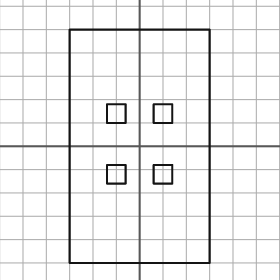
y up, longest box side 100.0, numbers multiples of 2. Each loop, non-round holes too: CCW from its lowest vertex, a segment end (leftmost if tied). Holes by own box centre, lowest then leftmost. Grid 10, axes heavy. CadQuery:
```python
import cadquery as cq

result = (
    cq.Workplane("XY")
    .moveTo(-30.0, -50.0)
    .lineTo(30.0, -50.0)
    .lineTo(30.0, 50.0)
    .lineTo(-30.0, 50.0)
    .close()
    .moveTo(-14.0, -16.0)
    .lineTo(-6.0, -16.0)
    .lineTo(-6.0, -8.0)
    .lineTo(-14.0, -8.0)
    .close()
    .moveTo(6.0, -16.0)
    .lineTo(14.0, -16.0)
    .lineTo(14.0, -8.0)
    .lineTo(6.0, -8.0)
    .close()
    .moveTo(-14.0, 10.0)
    .lineTo(-6.0, 10.0)
    .lineTo(-6.0, 18.0)
    .lineTo(-14.0, 18.0)
    .close()
    .moveTo(6.0, 10.0)
    .lineTo(14.0, 10.0)
    .lineTo(14.0, 18.0)
    .lineTo(6.0, 18.0)
    .close()
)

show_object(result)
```